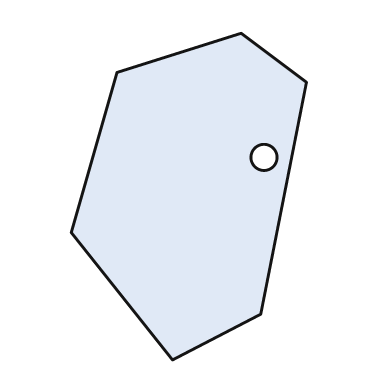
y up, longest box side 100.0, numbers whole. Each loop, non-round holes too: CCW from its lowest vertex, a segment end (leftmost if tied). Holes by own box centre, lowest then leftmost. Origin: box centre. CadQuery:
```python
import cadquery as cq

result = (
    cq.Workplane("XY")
    .moveTo(-5.0, -50.0)
    .lineTo(22.0, -36.0)
    .lineTo(36.0, 35.0)
    .lineTo(16.0, 50.0)
    .lineTo(-22.0, 38.0)
    .lineTo(-36.0, -11.0)
    .close()
    .moveTo(23.0, 12.0)
    .circle(4.0)
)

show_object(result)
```